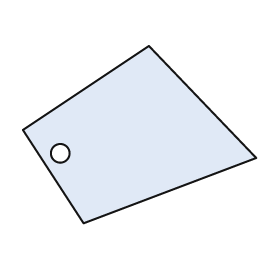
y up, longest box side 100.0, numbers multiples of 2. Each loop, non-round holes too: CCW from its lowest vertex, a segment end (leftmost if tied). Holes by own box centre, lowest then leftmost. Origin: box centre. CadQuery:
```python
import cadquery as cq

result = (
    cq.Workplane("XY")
    .moveTo(-24.0, -38.0)
    .lineTo(50.0, -10.0)
    .lineTo(4.0, 38.0)
    .lineTo(-50.0, 2.0)
    .close()
    .moveTo(-34.0, -8.0)
    .circle(4.0)
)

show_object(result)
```